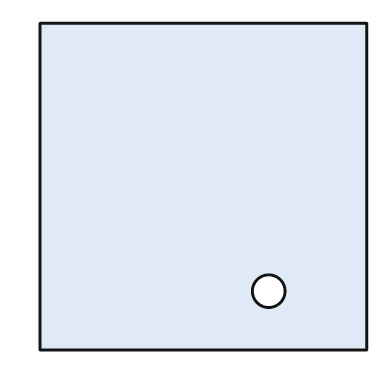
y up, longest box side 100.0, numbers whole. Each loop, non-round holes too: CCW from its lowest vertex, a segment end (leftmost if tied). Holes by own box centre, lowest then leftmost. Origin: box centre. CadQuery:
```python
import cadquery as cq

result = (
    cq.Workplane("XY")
    .moveTo(-50.0, -50.0)
    .lineTo(50.0, -50.0)
    .lineTo(50.0, 50.0)
    .lineTo(-50.0, 50.0)
    .close()
    .moveTo(20.0, -32.0)
    .circle(5.0)
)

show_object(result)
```